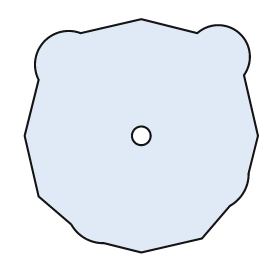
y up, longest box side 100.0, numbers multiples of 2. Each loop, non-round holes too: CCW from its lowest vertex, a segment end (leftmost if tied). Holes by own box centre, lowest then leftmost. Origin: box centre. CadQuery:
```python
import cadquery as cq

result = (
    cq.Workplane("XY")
    .moveTo(0.0, -50.0)
    .lineTo(26.0, -44.0)
    .lineTo(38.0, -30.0)
    .threePointArc((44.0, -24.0), (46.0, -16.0))
    .lineTo(50.0, 0.0)
    .lineTo(44.0, 26.0)
    .threePointArc((42.0, 44.0), (24.0, 44.0))
    .lineTo(0.0, 50.0)
    .lineTo(-26.0, 44.0)
    .threePointArc((-42.0, 40.0), (-44.0, 24.0))
    .lineTo(-50.0, 0.0)
    .lineTo(-44.0, -26.0)
    .lineTo(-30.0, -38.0)
    .threePointArc((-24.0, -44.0), (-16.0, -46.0))
    .close()
    .moveTo(0.0, 0.0)
    .circle(4.0)
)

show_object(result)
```